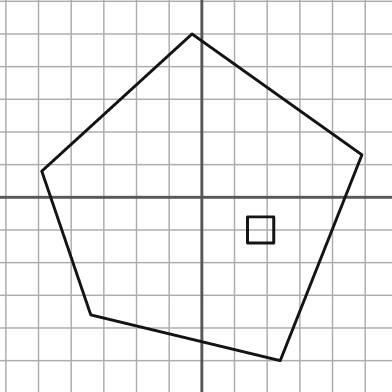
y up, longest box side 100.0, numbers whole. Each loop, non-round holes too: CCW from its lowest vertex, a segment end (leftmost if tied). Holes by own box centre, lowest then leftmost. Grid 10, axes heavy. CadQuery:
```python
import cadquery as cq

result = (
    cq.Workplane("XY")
    .moveTo(24.0, -50.0)
    .lineTo(49.0, 13.0)
    .lineTo(-3.0, 50.0)
    .lineTo(-49.0, 8.0)
    .lineTo(-34.0, -36.0)
    .close()
    .moveTo(14.0, -14.0)
    .lineTo(22.0, -14.0)
    .lineTo(22.0, -6.0)
    .lineTo(14.0, -6.0)
    .close()
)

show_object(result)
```